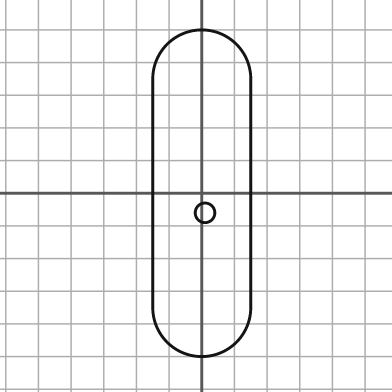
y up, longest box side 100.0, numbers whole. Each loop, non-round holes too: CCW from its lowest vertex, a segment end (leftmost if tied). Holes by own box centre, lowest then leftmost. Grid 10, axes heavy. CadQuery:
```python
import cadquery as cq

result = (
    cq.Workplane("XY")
    .moveTo(-15.0, -35.0)
    .threePointArc((0.0, -50.0), (15.0, -35.0))
    .lineTo(15.0, 35.0)
    .threePointArc((0.0, 50.0), (-15.0, 35.0))
    .close()
    .moveTo(1.0, -6.0)
    .circle(3.0)
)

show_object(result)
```